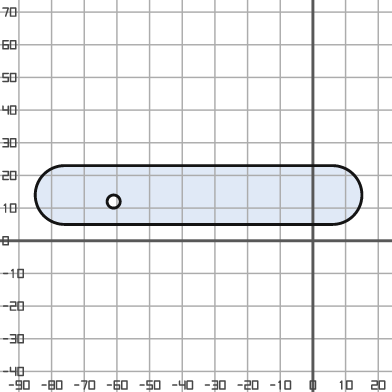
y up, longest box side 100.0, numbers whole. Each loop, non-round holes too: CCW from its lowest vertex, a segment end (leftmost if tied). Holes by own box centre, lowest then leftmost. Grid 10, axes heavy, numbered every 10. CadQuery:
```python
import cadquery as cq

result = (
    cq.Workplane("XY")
    .moveTo(-76.0, 5.0)
    .lineTo(6.0, 5.0)
    .threePointArc((15.0, 14.0), (6.0, 23.0))
    .lineTo(-76.0, 23.0)
    .threePointArc((-85.0, 14.0), (-76.0, 5.0))
    .close()
    .moveTo(-61.0, 12.0)
    .circle(2.0)
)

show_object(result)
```